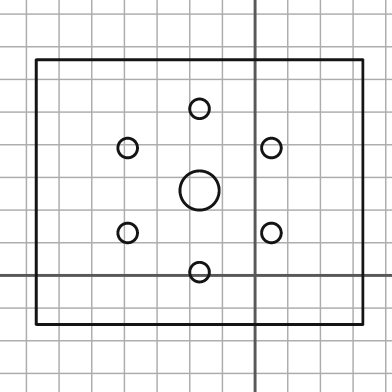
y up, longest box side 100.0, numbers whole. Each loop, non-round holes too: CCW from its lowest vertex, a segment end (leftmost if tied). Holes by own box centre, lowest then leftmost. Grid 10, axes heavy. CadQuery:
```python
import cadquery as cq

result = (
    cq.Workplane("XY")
    .moveTo(-67.0, -15.0)
    .lineTo(33.0, -15.0)
    .lineTo(33.0, 66.0)
    .lineTo(-67.0, 66.0)
    .close()
    .moveTo(-17.0, 1.0)
    .circle(3.0)
    .moveTo(-39.0, 13.0)
    .circle(3.0)
    .moveTo(5.0, 13.0)
    .circle(3.0)
    .moveTo(-17.0, 26.0)
    .circle(6.0)
    .moveTo(-39.0, 39.0)
    .circle(3.0)
    .moveTo(5.0, 39.0)
    .circle(3.0)
    .moveTo(-17.0, 51.0)
    .circle(3.0)
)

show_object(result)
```